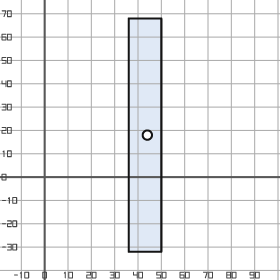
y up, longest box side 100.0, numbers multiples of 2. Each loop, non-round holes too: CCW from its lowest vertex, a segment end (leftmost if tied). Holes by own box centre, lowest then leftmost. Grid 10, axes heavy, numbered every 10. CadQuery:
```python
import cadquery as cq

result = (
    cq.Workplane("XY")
    .moveTo(36.0, -32.0)
    .lineTo(50.0, -32.0)
    .lineTo(50.0, 68.0)
    .lineTo(36.0, 68.0)
    .close()
    .moveTo(44.0, 18.0)
    .circle(2.0)
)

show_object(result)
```